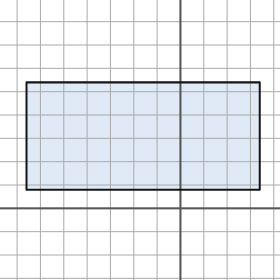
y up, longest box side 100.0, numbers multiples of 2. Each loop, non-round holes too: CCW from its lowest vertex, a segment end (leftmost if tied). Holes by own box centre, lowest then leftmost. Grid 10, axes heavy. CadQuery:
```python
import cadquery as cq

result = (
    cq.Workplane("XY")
    .moveTo(-66.0, 8.0)
    .lineTo(34.0, 8.0)
    .lineTo(34.0, 54.0)
    .lineTo(-66.0, 54.0)
    .close()
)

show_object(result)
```